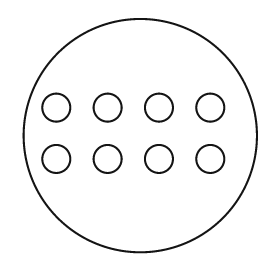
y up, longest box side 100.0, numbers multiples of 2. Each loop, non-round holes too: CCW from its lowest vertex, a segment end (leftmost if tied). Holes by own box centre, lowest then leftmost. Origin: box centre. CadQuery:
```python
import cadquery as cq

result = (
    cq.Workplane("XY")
    .moveTo(0.0, 0.0)
    .circle(50.0)
    .moveTo(-36.0, -10.0)
    .circle(6.0)
    .moveTo(-14.0, -10.0)
    .circle(6.0)
    .moveTo(8.0, -10.0)
    .circle(6.0)
    .moveTo(30.0, -10.0)
    .circle(6.0)
    .moveTo(-36.0, 12.0)
    .circle(6.0)
    .moveTo(-14.0, 12.0)
    .circle(6.0)
    .moveTo(8.0, 12.0)
    .circle(6.0)
    .moveTo(30.0, 12.0)
    .circle(6.0)
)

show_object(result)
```